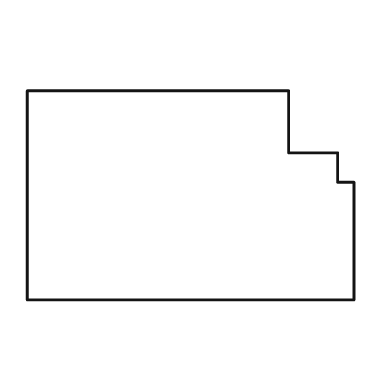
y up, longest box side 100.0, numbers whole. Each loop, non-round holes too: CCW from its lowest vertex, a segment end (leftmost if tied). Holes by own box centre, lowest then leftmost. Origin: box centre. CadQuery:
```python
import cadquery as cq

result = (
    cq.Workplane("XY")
    .moveTo(-50.0, -32.0)
    .lineTo(50.0, -32.0)
    .lineTo(50.0, 4.0)
    .lineTo(45.0, 4.0)
    .lineTo(45.0, 13.0)
    .lineTo(30.0, 13.0)
    .lineTo(30.0, 32.0)
    .lineTo(-50.0, 32.0)
    .close()
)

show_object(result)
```